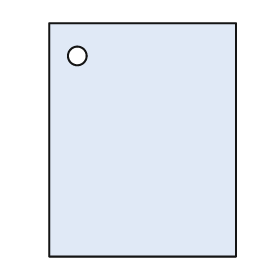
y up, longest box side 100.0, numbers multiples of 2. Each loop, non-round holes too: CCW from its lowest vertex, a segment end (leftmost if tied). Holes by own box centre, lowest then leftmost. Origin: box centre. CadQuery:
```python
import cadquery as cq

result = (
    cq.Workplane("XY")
    .moveTo(-40.0, -50.0)
    .lineTo(40.0, -50.0)
    .lineTo(40.0, 50.0)
    .lineTo(-40.0, 50.0)
    .close()
    .moveTo(-28.0, 36.0)
    .circle(4.0)
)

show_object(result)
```